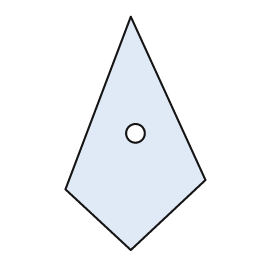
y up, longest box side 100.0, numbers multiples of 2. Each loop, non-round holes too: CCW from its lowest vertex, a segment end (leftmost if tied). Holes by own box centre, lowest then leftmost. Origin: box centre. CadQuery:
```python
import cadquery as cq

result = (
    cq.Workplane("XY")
    .moveTo(-2.0, -50.0)
    .lineTo(30.0, -20.0)
    .lineTo(-2.0, 50.0)
    .lineTo(-30.0, -24.0)
    .close()
    .moveTo(0.0, 0.0)
    .circle(4.0)
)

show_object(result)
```